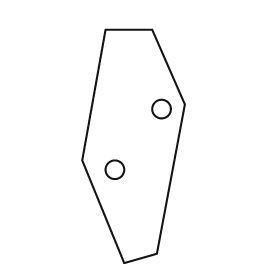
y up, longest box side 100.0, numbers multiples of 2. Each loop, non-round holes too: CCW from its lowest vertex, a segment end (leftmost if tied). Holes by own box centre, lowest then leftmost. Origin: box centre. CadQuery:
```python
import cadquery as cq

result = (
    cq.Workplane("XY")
    .moveTo(-4.0, -50.0)
    .lineTo(10.0, -46.0)
    .lineTo(22.0, 18.0)
    .lineTo(8.0, 50.0)
    .lineTo(-12.0, 50.0)
    .lineTo(-22.0, -6.0)
    .close()
    .moveTo(-8.0, -10.0)
    .circle(4.0)
    .moveTo(12.0, 16.0)
    .circle(4.0)
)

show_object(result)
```